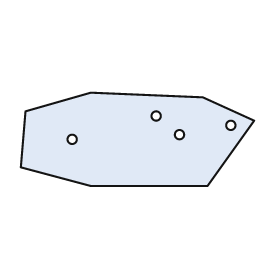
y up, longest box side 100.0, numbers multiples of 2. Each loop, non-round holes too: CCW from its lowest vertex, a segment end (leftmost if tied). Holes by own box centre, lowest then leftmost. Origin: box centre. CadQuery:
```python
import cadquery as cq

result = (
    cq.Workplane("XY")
    .moveTo(-20.0, -20.0)
    .lineTo(30.0, -20.0)
    .lineTo(50.0, 8.0)
    .lineTo(28.0, 18.0)
    .lineTo(-20.0, 20.0)
    .lineTo(-48.0, 12.0)
    .lineTo(-50.0, -12.0)
    .close()
    .moveTo(-28.0, 0.0)
    .circle(2.0)
    .moveTo(18.0, 2.0)
    .circle(2.0)
    .moveTo(40.0, 6.0)
    .circle(2.0)
    .moveTo(8.0, 10.0)
    .circle(2.0)
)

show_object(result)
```